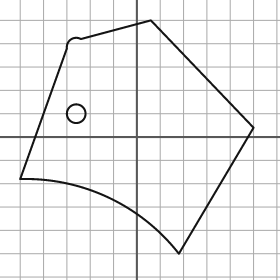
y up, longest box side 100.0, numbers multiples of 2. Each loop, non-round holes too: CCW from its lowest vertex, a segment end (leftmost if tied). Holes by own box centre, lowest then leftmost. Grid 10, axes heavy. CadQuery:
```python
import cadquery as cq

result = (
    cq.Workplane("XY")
    .moveTo(18.0, -50.0)
    .lineTo(50.0, 4.0)
    .lineTo(6.0, 50.0)
    .lineTo(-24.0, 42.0)
    .threePointArc((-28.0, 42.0), (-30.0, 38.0))
    .lineTo(-50.0, -18.0)
    .threePointArc((-12.0, -26.0), (18.0, -50.0))
    .close()
    .moveTo(-26.0, 10.0)
    .circle(4.0)
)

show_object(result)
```